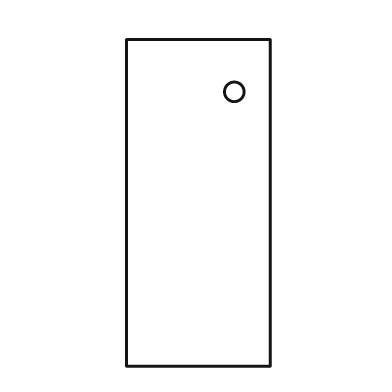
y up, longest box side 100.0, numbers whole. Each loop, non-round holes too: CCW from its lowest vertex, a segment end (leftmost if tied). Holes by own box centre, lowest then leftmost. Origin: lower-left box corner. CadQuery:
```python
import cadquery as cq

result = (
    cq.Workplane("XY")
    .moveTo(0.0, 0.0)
    .lineTo(44.0, 0.0)
    .lineTo(44.0, 100.0)
    .lineTo(0.0, 100.0)
    .close()
    .moveTo(33.0, 84.0)
    .circle(3.0)
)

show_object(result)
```